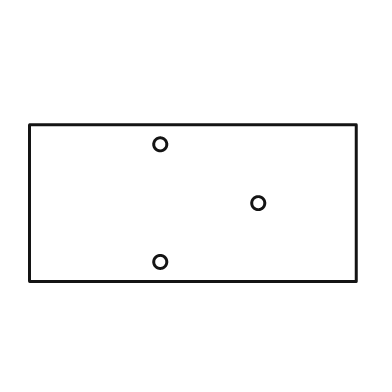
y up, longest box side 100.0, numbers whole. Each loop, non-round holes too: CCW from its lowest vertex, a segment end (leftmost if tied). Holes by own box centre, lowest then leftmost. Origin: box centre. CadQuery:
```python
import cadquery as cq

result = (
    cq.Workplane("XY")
    .moveTo(-50.0, -24.0)
    .lineTo(50.0, -24.0)
    .lineTo(50.0, 24.0)
    .lineTo(-50.0, 24.0)
    .close()
    .moveTo(-10.0, -18.0)
    .circle(2.0)
    .moveTo(20.0, 0.0)
    .circle(2.0)
    .moveTo(-10.0, 18.0)
    .circle(2.0)
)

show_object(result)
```